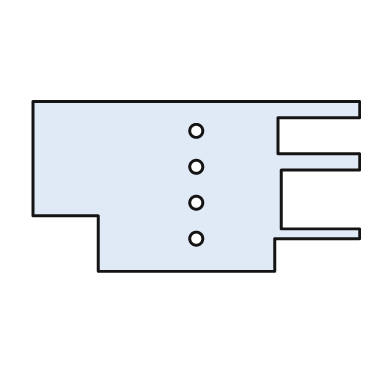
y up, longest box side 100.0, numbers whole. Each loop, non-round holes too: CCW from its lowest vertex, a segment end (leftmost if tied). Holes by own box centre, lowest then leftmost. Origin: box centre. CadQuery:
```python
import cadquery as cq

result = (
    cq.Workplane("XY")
    .moveTo(-30.0, -26.0)
    .lineTo(24.0, -26.0)
    .lineTo(24.0, -16.0)
    .lineTo(50.0, -16.0)
    .lineTo(50.0, -13.0)
    .lineTo(26.0, -13.0)
    .lineTo(26.0, 5.0)
    .lineTo(50.0, 5.0)
    .lineTo(50.0, 10.0)
    .lineTo(25.0, 10.0)
    .lineTo(25.0, 21.0)
    .lineTo(50.0, 21.0)
    .lineTo(50.0, 26.0)
    .lineTo(-50.0, 26.0)
    .lineTo(-50.0, -9.0)
    .lineTo(-30.0, -9.0)
    .close()
    .moveTo(0.0, -16.0)
    .circle(2.0)
    .moveTo(0.0, -5.0)
    .circle(2.0)
    .moveTo(0.0, 6.0)
    .circle(2.0)
    .moveTo(0.0, 17.0)
    .circle(2.0)
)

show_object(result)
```